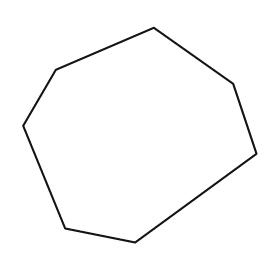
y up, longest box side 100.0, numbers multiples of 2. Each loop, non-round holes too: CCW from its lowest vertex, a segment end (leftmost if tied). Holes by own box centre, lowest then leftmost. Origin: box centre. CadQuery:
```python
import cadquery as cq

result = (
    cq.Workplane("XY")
    .moveTo(-2.0, -46.0)
    .lineTo(50.0, -8.0)
    .lineTo(40.0, 22.0)
    .lineTo(6.0, 46.0)
    .lineTo(-36.0, 28.0)
    .lineTo(-50.0, 4.0)
    .lineTo(-32.0, -40.0)
    .close()
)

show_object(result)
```